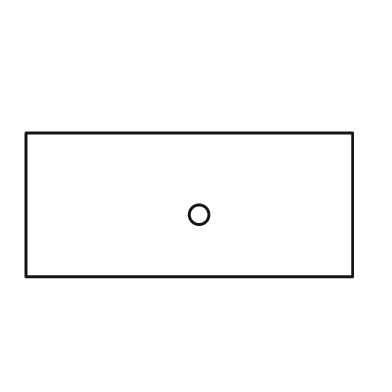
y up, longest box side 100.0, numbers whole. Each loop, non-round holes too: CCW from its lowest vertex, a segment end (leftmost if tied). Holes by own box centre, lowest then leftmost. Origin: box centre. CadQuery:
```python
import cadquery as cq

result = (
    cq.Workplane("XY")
    .moveTo(-50.0, -22.0)
    .lineTo(50.0, -22.0)
    .lineTo(50.0, 22.0)
    .lineTo(-50.0, 22.0)
    .close()
    .moveTo(3.0, -3.0)
    .circle(3.0)
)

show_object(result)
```